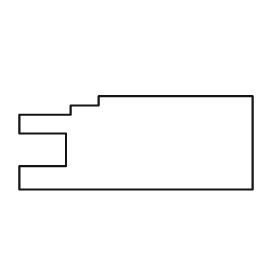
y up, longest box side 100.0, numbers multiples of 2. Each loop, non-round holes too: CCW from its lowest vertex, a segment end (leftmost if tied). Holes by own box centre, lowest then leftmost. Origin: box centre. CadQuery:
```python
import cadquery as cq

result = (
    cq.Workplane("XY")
    .moveTo(-50.0, -20.0)
    .lineTo(50.0, -20.0)
    .lineTo(50.0, 20.0)
    .lineTo(-16.0, 20.0)
    .lineTo(-16.0, 16.0)
    .lineTo(-28.0, 16.0)
    .lineTo(-28.0, 12.0)
    .lineTo(-50.0, 12.0)
    .lineTo(-50.0, 4.0)
    .lineTo(-30.0, 4.0)
    .lineTo(-30.0, -10.0)
    .lineTo(-50.0, -10.0)
    .close()
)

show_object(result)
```